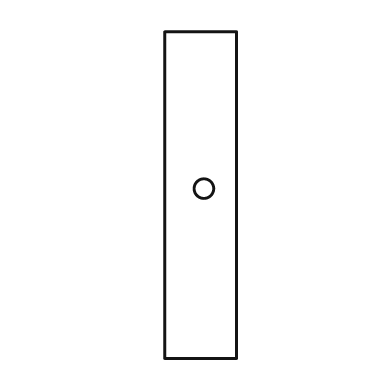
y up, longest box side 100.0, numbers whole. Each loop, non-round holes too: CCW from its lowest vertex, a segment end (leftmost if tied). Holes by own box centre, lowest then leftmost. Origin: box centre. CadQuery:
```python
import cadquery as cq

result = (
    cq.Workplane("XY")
    .moveTo(-11.0, -50.0)
    .lineTo(11.0, -50.0)
    .lineTo(11.0, 50.0)
    .lineTo(-11.0, 50.0)
    .close()
    .moveTo(1.0, 2.0)
    .circle(3.0)
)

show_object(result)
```